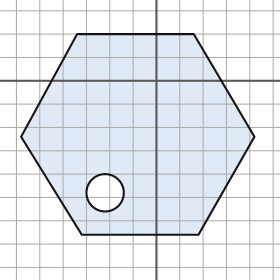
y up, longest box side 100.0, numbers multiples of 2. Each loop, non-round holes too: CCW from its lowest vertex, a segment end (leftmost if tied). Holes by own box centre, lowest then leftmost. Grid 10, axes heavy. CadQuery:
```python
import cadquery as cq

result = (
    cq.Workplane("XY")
    .moveTo(-32.0, -66.0)
    .lineTo(18.0, -66.0)
    .lineTo(42.0, -24.0)
    .lineTo(16.0, 20.0)
    .lineTo(-34.0, 20.0)
    .lineTo(-58.0, -24.0)
    .close()
    .moveTo(-22.0, -48.0)
    .circle(8.0)
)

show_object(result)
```